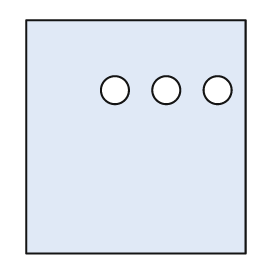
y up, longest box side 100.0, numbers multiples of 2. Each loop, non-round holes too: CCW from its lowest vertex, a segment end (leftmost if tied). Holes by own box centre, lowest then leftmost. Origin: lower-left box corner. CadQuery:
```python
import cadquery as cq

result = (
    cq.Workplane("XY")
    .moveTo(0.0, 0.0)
    .lineTo(94.0, 0.0)
    .lineTo(94.0, 100.0)
    .lineTo(0.0, 100.0)
    .close()
    .moveTo(38.0, 70.0)
    .circle(6.0)
    .moveTo(60.0, 70.0)
    .circle(6.0)
    .moveTo(82.0, 70.0)
    .circle(6.0)
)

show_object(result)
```